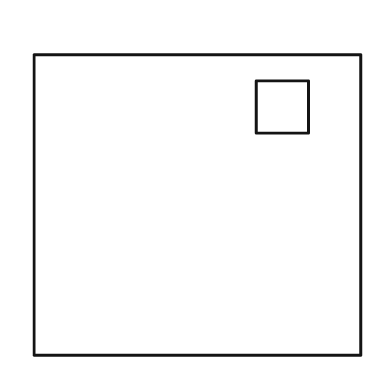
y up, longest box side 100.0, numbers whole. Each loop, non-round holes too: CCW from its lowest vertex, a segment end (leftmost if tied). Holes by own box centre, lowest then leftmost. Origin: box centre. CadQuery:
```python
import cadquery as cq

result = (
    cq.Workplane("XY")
    .moveTo(-50.0, -46.0)
    .lineTo(50.0, -46.0)
    .lineTo(50.0, 46.0)
    .lineTo(-50.0, 46.0)
    .close()
    .moveTo(18.0, 22.0)
    .lineTo(34.0, 22.0)
    .lineTo(34.0, 38.0)
    .lineTo(18.0, 38.0)
    .close()
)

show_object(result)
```